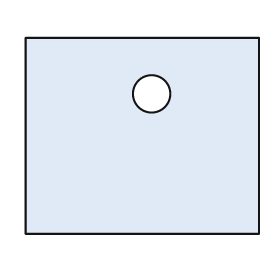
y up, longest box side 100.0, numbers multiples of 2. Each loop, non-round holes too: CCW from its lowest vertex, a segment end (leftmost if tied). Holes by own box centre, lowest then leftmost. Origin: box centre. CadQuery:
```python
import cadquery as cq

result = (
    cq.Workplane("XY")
    .moveTo(-50.0, -42.0)
    .lineTo(50.0, -42.0)
    .lineTo(50.0, 42.0)
    .lineTo(-50.0, 42.0)
    .close()
    .moveTo(4.0, 18.0)
    .circle(8.0)
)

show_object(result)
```